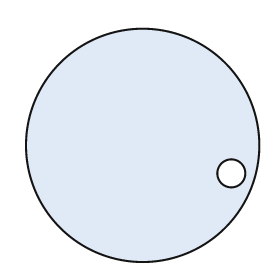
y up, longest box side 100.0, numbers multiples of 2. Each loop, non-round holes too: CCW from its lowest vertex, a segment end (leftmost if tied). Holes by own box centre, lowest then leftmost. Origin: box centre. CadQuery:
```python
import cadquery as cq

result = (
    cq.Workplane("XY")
    .moveTo(0.0, 0.0)
    .circle(50.0)
    .moveTo(38.0, -12.0)
    .circle(6.0)
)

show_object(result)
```